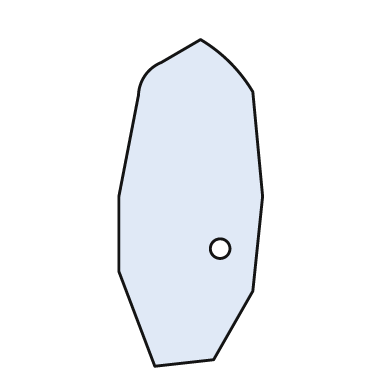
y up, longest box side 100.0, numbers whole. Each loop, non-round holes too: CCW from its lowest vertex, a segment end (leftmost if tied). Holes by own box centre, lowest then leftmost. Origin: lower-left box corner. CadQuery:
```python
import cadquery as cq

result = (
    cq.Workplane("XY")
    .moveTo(11.0, 0.0)
    .lineTo(29.0, 2.0)
    .lineTo(41.0, 23.0)
    .lineTo(44.0, 52.0)
    .lineTo(41.0, 84.0)
    .threePointArc((34.0, 93.0), (25.0, 100.0))
    .lineTo(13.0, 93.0)
    .threePointArc((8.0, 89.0), (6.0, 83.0))
    .lineTo(0.0, 52.0)
    .lineTo(0.0, 29.0)
    .close()
    .moveTo(31.0, 36.0)
    .circle(3.0)
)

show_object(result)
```